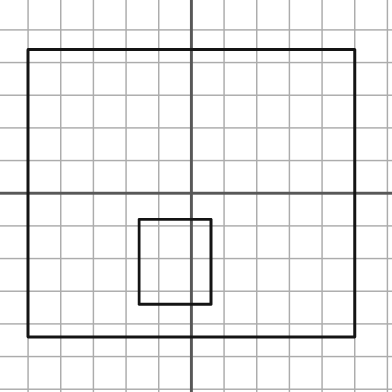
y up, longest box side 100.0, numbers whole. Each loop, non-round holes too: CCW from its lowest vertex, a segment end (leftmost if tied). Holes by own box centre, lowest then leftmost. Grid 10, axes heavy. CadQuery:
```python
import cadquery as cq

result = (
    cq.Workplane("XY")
    .moveTo(-50.0, -44.0)
    .lineTo(50.0, -44.0)
    .lineTo(50.0, 44.0)
    .lineTo(-50.0, 44.0)
    .close()
    .moveTo(-16.0, -34.0)
    .lineTo(6.0, -34.0)
    .lineTo(6.0, -8.0)
    .lineTo(-16.0, -8.0)
    .close()
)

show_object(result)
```